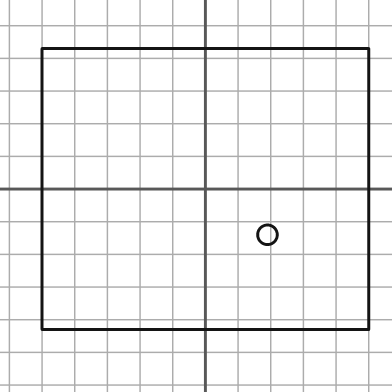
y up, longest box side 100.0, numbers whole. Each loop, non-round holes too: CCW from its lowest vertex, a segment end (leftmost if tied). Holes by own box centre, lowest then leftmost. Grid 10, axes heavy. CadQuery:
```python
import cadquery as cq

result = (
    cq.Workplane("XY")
    .moveTo(-50.0, -43.0)
    .lineTo(50.0, -43.0)
    .lineTo(50.0, 43.0)
    .lineTo(-50.0, 43.0)
    .close()
    .moveTo(19.0, -14.0)
    .circle(3.0)
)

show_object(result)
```